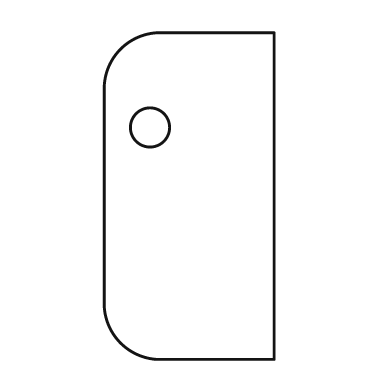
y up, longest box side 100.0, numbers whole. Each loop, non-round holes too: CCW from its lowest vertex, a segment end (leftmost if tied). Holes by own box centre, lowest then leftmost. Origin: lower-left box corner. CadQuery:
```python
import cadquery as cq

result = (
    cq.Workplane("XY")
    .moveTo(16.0, 0.0)
    .lineTo(52.0, 0.0)
    .lineTo(52.0, 100.0)
    .lineTo(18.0, 100.0)
    .threePointArc((5.0, 95.0), (0.0, 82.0))
    .lineTo(0.0, 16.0)
    .threePointArc((5.0, 5.0), (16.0, 0.0))
    .close()
    .moveTo(14.0, 71.0)
    .circle(6.0)
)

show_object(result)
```